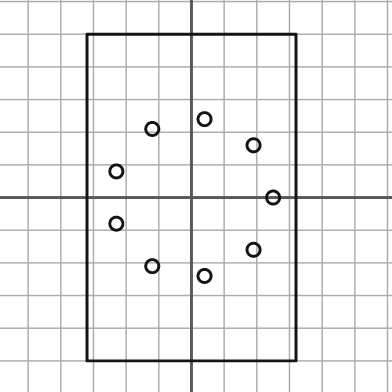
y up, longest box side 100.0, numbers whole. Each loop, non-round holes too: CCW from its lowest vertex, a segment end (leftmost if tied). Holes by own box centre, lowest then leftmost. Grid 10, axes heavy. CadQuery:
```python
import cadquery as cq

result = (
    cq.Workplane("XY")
    .moveTo(-32.0, -50.0)
    .lineTo(32.0, -50.0)
    .lineTo(32.0, 50.0)
    .lineTo(-32.0, 50.0)
    .close()
    .moveTo(4.0, -24.0)
    .circle(2.0)
    .moveTo(-12.0, -21.0)
    .circle(2.0)
    .moveTo(19.0, -16.0)
    .circle(2.0)
    .moveTo(-23.0, -8.0)
    .circle(2.0)
    .moveTo(25.0, 0.0)
    .circle(2.0)
    .moveTo(-23.0, 8.0)
    .circle(2.0)
    .moveTo(19.0, 16.0)
    .circle(2.0)
    .moveTo(-12.0, 21.0)
    .circle(2.0)
    .moveTo(4.0, 24.0)
    .circle(2.0)
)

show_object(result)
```